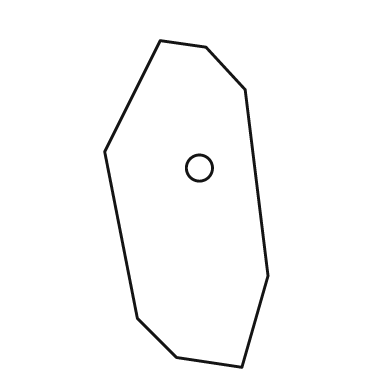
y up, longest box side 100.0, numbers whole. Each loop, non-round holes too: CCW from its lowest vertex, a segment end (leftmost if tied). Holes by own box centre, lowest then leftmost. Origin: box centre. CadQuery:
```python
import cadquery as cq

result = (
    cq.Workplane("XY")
    .moveTo(17.0, -50.0)
    .lineTo(25.0, -22.0)
    .lineTo(18.0, 35.0)
    .lineTo(6.0, 48.0)
    .lineTo(-8.0, 50.0)
    .lineTo(-25.0, 16.0)
    .lineTo(-15.0, -35.0)
    .lineTo(-3.0, -47.0)
    .close()
    .moveTo(4.0, 11.0)
    .circle(4.0)
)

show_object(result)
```